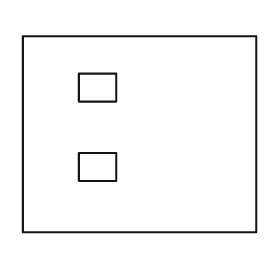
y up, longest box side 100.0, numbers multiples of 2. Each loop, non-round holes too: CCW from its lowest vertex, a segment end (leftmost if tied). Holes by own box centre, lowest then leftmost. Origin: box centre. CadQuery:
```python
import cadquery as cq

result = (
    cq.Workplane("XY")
    .moveTo(-50.0, -42.0)
    .lineTo(50.0, -42.0)
    .lineTo(50.0, 42.0)
    .lineTo(-50.0, 42.0)
    .close()
    .moveTo(-26.0, -20.0)
    .lineTo(-10.0, -20.0)
    .lineTo(-10.0, -8.0)
    .lineTo(-26.0, -8.0)
    .close()
    .moveTo(-26.0, 14.0)
    .lineTo(-10.0, 14.0)
    .lineTo(-10.0, 26.0)
    .lineTo(-26.0, 26.0)
    .close()
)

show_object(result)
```